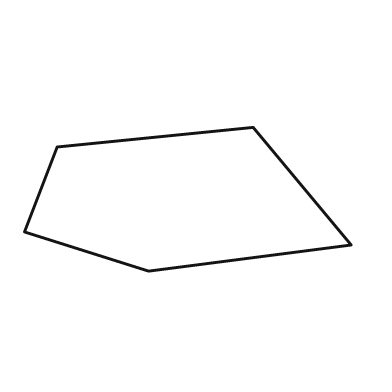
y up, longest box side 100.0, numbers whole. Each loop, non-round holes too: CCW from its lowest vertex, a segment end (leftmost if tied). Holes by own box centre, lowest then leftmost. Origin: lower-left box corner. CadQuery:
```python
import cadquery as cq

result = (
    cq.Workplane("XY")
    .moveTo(38.0, 0.0)
    .lineTo(100.0, 8.0)
    .lineTo(70.0, 44.0)
    .lineTo(10.0, 38.0)
    .lineTo(0.0, 12.0)
    .close()
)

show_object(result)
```